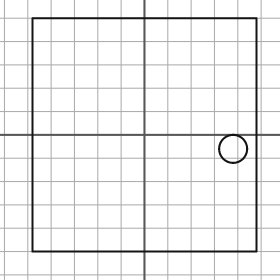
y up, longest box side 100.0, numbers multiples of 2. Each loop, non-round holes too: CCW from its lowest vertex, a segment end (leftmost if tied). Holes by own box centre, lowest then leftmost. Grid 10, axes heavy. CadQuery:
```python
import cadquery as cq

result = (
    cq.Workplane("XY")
    .moveTo(-48.0, -50.0)
    .lineTo(48.0, -50.0)
    .lineTo(48.0, 50.0)
    .lineTo(-48.0, 50.0)
    .close()
    .moveTo(38.0, -6.0)
    .circle(6.0)
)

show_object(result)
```